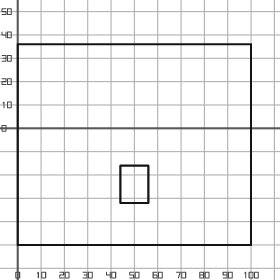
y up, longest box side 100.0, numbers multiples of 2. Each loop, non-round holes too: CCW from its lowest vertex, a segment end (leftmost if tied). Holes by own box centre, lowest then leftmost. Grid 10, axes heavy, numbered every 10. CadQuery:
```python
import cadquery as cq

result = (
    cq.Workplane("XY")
    .moveTo(0.0, -50.0)
    .lineTo(100.0, -50.0)
    .lineTo(100.0, 36.0)
    .lineTo(0.0, 36.0)
    .close()
    .moveTo(44.0, -32.0)
    .lineTo(56.0, -32.0)
    .lineTo(56.0, -16.0)
    .lineTo(44.0, -16.0)
    .close()
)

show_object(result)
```